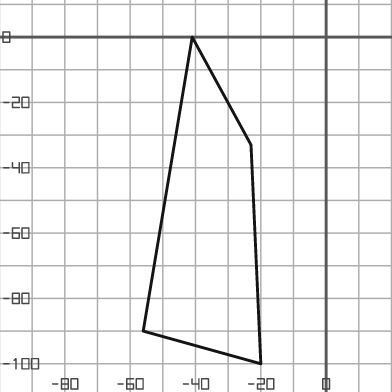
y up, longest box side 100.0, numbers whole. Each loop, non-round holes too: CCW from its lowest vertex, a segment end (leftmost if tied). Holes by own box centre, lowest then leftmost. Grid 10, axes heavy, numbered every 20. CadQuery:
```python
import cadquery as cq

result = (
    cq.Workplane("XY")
    .moveTo(-20.0, -100.0)
    .lineTo(-23.0, -33.0)
    .lineTo(-41.0, 0.0)
    .lineTo(-56.0, -90.0)
    .close()
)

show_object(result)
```